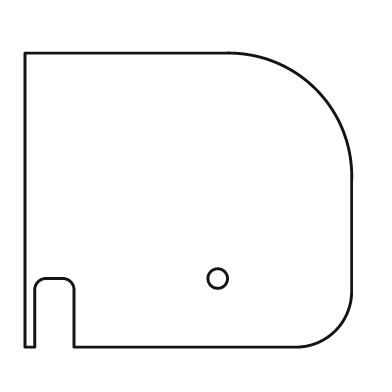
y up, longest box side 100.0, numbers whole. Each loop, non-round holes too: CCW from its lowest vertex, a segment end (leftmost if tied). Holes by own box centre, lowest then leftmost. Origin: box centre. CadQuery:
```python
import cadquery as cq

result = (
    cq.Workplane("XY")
    .moveTo(-50.0, -45.0)
    .lineTo(-47.0, -45.0)
    .lineTo(-47.0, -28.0)
    .threePointArc((-46.0, -25.0), (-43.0, -24.0))
    .lineTo(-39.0, -24.0)
    .threePointArc((-36.0, -25.0), (-35.0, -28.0))
    .lineTo(-35.0, -45.0)
    .lineTo(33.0, -45.0)
    .threePointArc((45.0, -40.0), (50.0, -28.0))
    .lineTo(50.0, 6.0)
    .threePointArc((39.0, 34.0), (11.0, 45.0))
    .lineTo(-50.0, 45.0)
    .close()
    .moveTo(9.0, -24.0)
    .circle(3.0)
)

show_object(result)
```